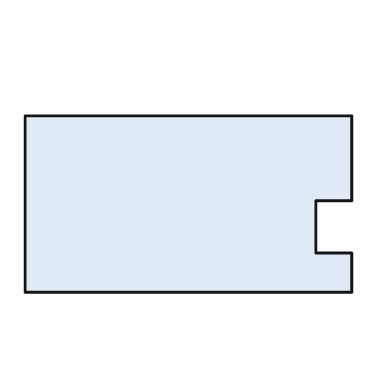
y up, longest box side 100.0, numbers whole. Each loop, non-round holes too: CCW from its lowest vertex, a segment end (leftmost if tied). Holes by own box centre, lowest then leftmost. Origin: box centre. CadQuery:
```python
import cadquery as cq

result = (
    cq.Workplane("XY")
    .moveTo(-50.0, -27.0)
    .lineTo(50.0, -27.0)
    .lineTo(50.0, -15.0)
    .lineTo(39.0, -15.0)
    .lineTo(39.0, 1.0)
    .lineTo(50.0, 1.0)
    .lineTo(50.0, 27.0)
    .lineTo(-50.0, 27.0)
    .close()
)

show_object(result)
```